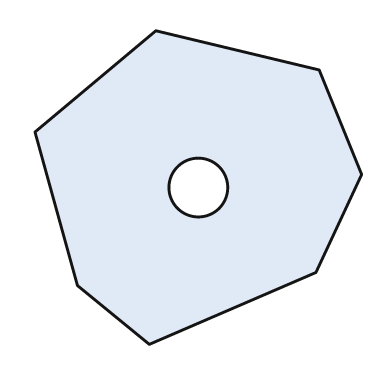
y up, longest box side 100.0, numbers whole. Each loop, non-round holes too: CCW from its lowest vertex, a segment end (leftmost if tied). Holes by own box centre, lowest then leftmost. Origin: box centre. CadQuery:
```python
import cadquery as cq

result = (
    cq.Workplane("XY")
    .moveTo(-15.0, -48.0)
    .lineTo(36.0, -26.0)
    .lineTo(50.0, 4.0)
    .lineTo(37.0, 36.0)
    .lineTo(-13.0, 48.0)
    .lineTo(-50.0, 17.0)
    .lineTo(-37.0, -30.0)
    .close()
    .moveTo(0.0, 0.0)
    .circle(9.0)
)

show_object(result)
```